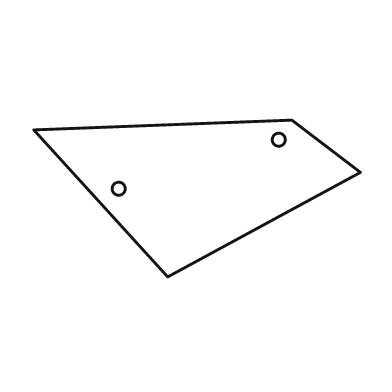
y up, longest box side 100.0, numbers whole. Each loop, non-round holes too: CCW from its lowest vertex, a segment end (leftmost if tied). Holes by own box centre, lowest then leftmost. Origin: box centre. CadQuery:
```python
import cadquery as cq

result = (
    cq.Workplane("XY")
    .moveTo(-9.0, -24.0)
    .lineTo(50.0, 8.0)
    .lineTo(29.0, 24.0)
    .lineTo(-50.0, 21.0)
    .close()
    .moveTo(-24.0, 3.0)
    .circle(2.0)
    .moveTo(25.0, 18.0)
    .circle(2.0)
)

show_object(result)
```